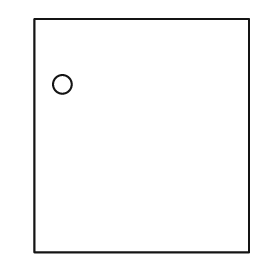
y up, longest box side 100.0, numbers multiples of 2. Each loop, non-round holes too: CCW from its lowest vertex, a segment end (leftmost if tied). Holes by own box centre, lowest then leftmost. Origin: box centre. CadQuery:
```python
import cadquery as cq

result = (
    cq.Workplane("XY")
    .moveTo(-46.0, -50.0)
    .lineTo(46.0, -50.0)
    .lineTo(46.0, 50.0)
    .lineTo(-46.0, 50.0)
    .close()
    .moveTo(-34.0, 22.0)
    .circle(4.0)
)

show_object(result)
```